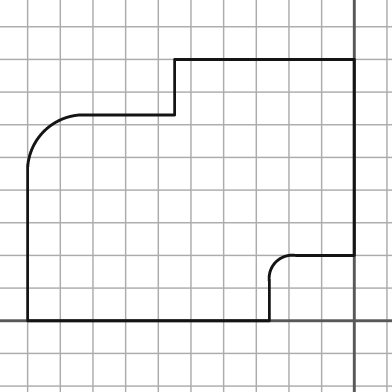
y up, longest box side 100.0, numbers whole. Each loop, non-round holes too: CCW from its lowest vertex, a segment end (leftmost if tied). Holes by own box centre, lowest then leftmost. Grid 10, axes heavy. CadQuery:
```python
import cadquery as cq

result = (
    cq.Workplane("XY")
    .moveTo(-100.0, 0.0)
    .lineTo(-26.0, 0.0)
    .lineTo(-26.0, 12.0)
    .threePointArc((-24.0, 18.0), (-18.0, 20.0))
    .lineTo(0.0, 20.0)
    .lineTo(0.0, 80.0)
    .lineTo(-55.0, 80.0)
    .lineTo(-55.0, 63.0)
    .lineTo(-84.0, 63.0)
    .threePointArc((-95.0, 58.0), (-100.0, 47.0))
    .close()
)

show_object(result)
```